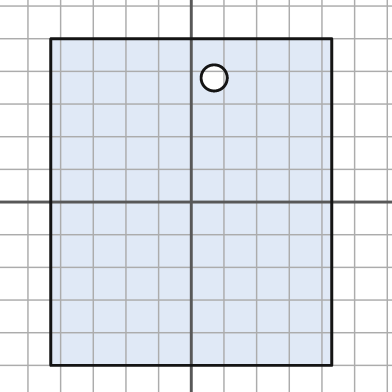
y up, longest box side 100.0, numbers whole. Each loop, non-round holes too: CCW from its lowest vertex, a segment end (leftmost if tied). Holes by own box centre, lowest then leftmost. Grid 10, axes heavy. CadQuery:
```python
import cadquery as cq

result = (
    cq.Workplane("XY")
    .moveTo(-43.0, -50.0)
    .lineTo(43.0, -50.0)
    .lineTo(43.0, 50.0)
    .lineTo(-43.0, 50.0)
    .close()
    .moveTo(7.0, 38.0)
    .circle(4.0)
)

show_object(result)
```